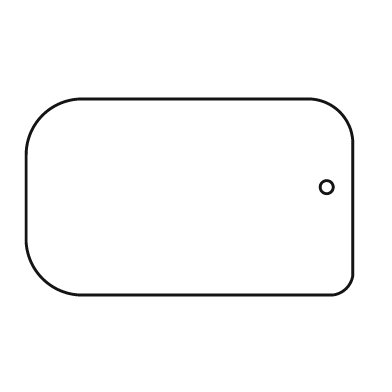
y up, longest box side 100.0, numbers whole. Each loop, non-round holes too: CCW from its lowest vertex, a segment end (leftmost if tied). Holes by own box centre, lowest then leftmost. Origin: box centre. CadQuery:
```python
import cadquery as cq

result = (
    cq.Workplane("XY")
    .moveTo(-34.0, -30.0)
    .lineTo(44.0, -30.0)
    .threePointArc((48.0, -28.0), (50.0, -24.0))
    .lineTo(50.0, 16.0)
    .threePointArc((46.0, 26.0), (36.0, 30.0))
    .lineTo(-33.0, 30.0)
    .threePointArc((-45.0, 25.0), (-50.0, 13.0))
    .lineTo(-50.0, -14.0)
    .threePointArc((-45.0, -25.0), (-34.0, -30.0))
    .close()
    .moveTo(42.0, 3.0)
    .circle(2.0)
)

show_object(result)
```